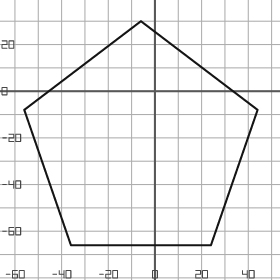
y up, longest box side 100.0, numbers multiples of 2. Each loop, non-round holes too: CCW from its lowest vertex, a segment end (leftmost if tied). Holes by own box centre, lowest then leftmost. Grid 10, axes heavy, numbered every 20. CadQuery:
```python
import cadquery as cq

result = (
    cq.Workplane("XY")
    .moveTo(-36.0, -66.0)
    .lineTo(24.0, -66.0)
    .lineTo(44.0, -8.0)
    .lineTo(-6.0, 30.0)
    .lineTo(-56.0, -8.0)
    .close()
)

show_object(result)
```